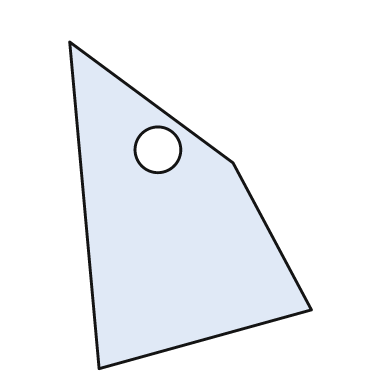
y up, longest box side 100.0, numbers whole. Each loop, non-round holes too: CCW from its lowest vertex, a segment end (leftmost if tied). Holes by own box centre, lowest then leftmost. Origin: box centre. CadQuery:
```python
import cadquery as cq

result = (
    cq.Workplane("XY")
    .moveTo(-28.0, -50.0)
    .lineTo(37.0, -32.0)
    .lineTo(13.0, 13.0)
    .lineTo(-37.0, 50.0)
    .close()
    .moveTo(-10.0, 17.0)
    .circle(7.0)
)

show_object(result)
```